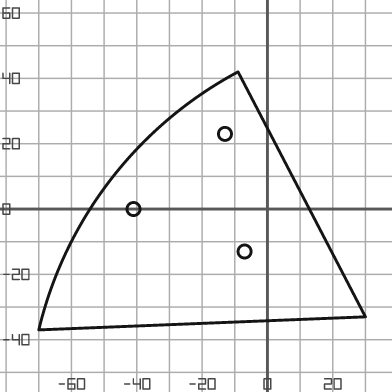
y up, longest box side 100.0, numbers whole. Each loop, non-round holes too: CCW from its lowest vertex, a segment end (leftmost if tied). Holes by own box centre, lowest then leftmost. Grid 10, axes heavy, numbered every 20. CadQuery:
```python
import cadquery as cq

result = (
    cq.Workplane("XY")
    .moveTo(-70.0, -37.0)
    .lineTo(30.0, -33.0)
    .lineTo(-9.0, 42.0)
    .threePointArc((-48.0, 9.0), (-70.0, -37.0))
    .close()
    .moveTo(-7.0, -13.0)
    .circle(2.0)
    .moveTo(-41.0, 0.0)
    .circle(2.0)
    .moveTo(-13.0, 23.0)
    .circle(2.0)
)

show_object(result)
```